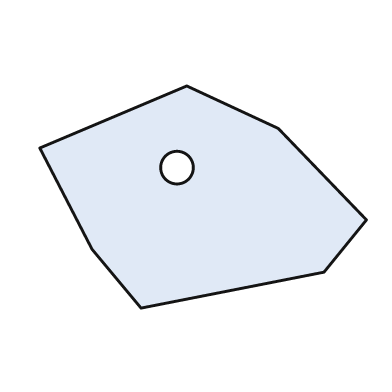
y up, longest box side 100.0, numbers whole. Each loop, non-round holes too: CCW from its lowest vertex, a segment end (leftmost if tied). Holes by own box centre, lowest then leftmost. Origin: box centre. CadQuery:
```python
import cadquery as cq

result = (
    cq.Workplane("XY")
    .moveTo(-19.0, -34.0)
    .lineTo(37.0, -23.0)
    .lineTo(50.0, -7.0)
    .lineTo(23.0, 21.0)
    .lineTo(-5.0, 34.0)
    .lineTo(-50.0, 15.0)
    .lineTo(-34.0, -16.0)
    .close()
    .moveTo(-8.0, 9.0)
    .circle(5.0)
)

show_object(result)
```